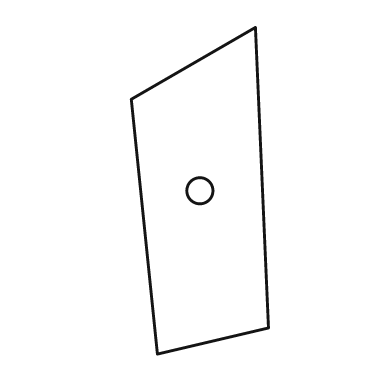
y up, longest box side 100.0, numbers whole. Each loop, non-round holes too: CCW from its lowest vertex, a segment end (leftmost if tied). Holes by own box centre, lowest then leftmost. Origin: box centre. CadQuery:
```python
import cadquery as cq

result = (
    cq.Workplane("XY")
    .moveTo(-13.0, -50.0)
    .lineTo(21.0, -42.0)
    .lineTo(17.0, 50.0)
    .lineTo(-21.0, 28.0)
    .close()
    .moveTo(0.0, 0.0)
    .circle(4.0)
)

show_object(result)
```